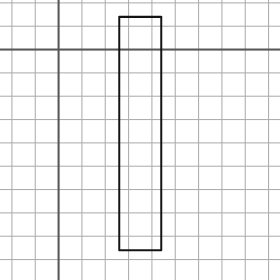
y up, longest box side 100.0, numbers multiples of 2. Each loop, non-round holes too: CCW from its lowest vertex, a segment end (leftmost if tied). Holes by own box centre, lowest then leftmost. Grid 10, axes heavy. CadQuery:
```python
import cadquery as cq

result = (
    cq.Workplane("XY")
    .moveTo(26.0, -86.0)
    .lineTo(44.0, -86.0)
    .lineTo(44.0, 14.0)
    .lineTo(26.0, 14.0)
    .close()
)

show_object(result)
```